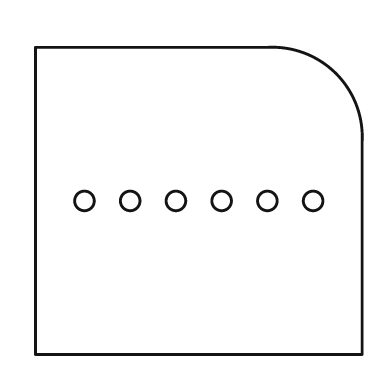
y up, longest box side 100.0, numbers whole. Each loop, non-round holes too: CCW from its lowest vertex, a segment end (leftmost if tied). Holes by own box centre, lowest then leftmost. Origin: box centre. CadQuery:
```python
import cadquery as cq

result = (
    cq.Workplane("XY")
    .moveTo(-50.0, -47.0)
    .lineTo(50.0, -47.0)
    .lineTo(50.0, 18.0)
    .threePointArc((42.0, 39.0), (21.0, 47.0))
    .lineTo(-50.0, 47.0)
    .close()
    .moveTo(-35.0, 0.0)
    .circle(3.0)
    .moveTo(-21.0, 0.0)
    .circle(3.0)
    .moveTo(-7.0, 0.0)
    .circle(3.0)
    .moveTo(7.0, 0.0)
    .circle(3.0)
    .moveTo(21.0, 0.0)
    .circle(3.0)
    .moveTo(35.0, 0.0)
    .circle(3.0)
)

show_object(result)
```